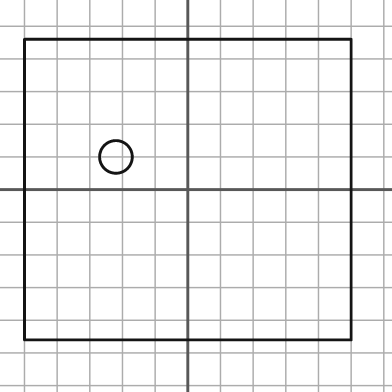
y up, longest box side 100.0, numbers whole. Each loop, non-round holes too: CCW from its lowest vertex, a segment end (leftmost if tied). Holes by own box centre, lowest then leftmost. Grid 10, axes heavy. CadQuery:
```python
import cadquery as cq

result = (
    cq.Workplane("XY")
    .moveTo(-50.0, -46.0)
    .lineTo(50.0, -46.0)
    .lineTo(50.0, 46.0)
    .lineTo(-50.0, 46.0)
    .close()
    .moveTo(-22.0, 10.0)
    .circle(5.0)
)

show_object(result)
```